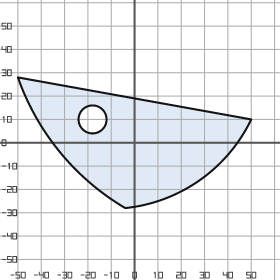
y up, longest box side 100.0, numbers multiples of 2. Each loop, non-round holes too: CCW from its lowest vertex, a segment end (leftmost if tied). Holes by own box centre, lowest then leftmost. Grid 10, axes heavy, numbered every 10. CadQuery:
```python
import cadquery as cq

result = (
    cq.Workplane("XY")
    .moveTo(-4.0, -28.0)
    .threePointArc((28.0, -16.0), (50.0, 10.0))
    .lineTo(-50.0, 28.0)
    .threePointArc((-32.0, -4.0), (-4.0, -28.0))
    .close()
    .moveTo(-18.0, 10.0)
    .circle(6.0)
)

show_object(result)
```